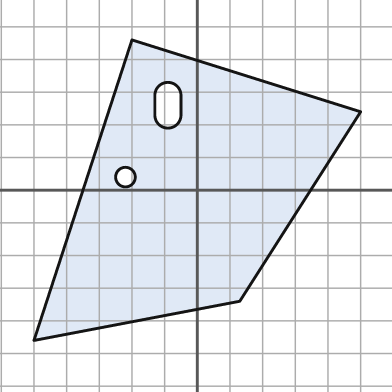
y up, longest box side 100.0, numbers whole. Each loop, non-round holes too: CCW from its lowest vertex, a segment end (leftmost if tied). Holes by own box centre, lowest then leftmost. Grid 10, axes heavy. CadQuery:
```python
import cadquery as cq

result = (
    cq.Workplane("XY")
    .moveTo(-50.0, -46.0)
    .lineTo(13.0, -34.0)
    .lineTo(50.0, 24.0)
    .lineTo(-20.0, 46.0)
    .close()
    .moveTo(-22.0, 4.0)
    .circle(3.0)
    .moveTo(-13.0, 23.0)
    .threePointArc((-9.0, 19.0), (-5.0, 23.0))
    .lineTo(-5.0, 29.0)
    .threePointArc((-9.0, 33.0), (-13.0, 29.0))
    .close()
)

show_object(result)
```